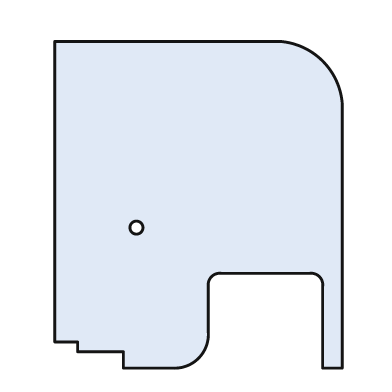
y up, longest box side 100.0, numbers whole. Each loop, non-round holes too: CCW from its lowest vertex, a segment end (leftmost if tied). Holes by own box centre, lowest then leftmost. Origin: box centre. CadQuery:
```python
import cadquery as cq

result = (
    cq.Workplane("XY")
    .moveTo(-23.0, -50.0)
    .lineTo(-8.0, -50.0)
    .threePointArc((0.0, -47.0), (3.0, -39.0))
    .lineTo(3.0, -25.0)
    .threePointArc((4.0, -22.0), (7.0, -21.0))
    .lineTo(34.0, -21.0)
    .threePointArc((37.0, -22.0), (38.0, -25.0))
    .lineTo(38.0, -50.0)
    .lineTo(44.0, -50.0)
    .lineTo(44.0, 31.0)
    .threePointArc((38.0, 44.0), (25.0, 50.0))
    .lineTo(-44.0, 50.0)
    .lineTo(-44.0, -42.0)
    .lineTo(-37.0, -42.0)
    .lineTo(-37.0, -45.0)
    .lineTo(-23.0, -45.0)
    .close()
    .moveTo(-19.0, -7.0)
    .circle(2.0)
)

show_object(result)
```